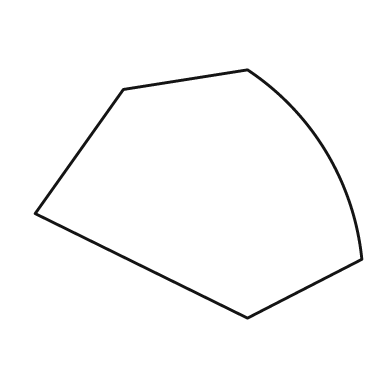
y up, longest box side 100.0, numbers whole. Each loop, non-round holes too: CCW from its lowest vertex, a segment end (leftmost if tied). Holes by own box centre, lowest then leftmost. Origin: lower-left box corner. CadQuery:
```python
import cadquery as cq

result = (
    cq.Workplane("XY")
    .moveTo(65.0, 0.0)
    .lineTo(100.0, 18.0)
    .threePointArc((89.0, 51.0), (65.0, 76.0))
    .lineTo(27.0, 70.0)
    .lineTo(0.0, 32.0)
    .close()
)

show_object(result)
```